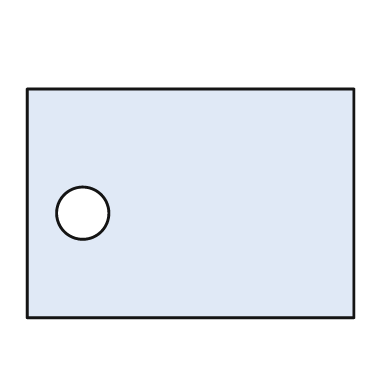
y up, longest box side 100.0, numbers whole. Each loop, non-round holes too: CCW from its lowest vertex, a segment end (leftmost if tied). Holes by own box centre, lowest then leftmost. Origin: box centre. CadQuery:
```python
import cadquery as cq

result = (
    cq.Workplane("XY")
    .moveTo(-50.0, -35.0)
    .lineTo(50.0, -35.0)
    .lineTo(50.0, 35.0)
    .lineTo(-50.0, 35.0)
    .close()
    .moveTo(-33.0, -3.0)
    .circle(8.0)
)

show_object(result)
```